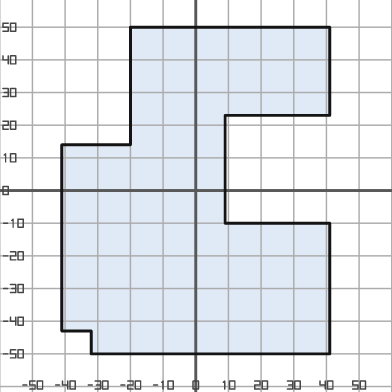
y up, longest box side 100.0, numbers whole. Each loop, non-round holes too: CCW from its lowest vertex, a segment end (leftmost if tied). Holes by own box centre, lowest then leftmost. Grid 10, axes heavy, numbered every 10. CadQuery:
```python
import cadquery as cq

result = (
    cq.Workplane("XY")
    .moveTo(-32.0, -50.0)
    .lineTo(41.0, -50.0)
    .lineTo(41.0, -10.0)
    .lineTo(9.0, -10.0)
    .lineTo(9.0, 23.0)
    .lineTo(41.0, 23.0)
    .lineTo(41.0, 50.0)
    .lineTo(-20.0, 50.0)
    .lineTo(-20.0, 14.0)
    .lineTo(-41.0, 14.0)
    .lineTo(-41.0, -43.0)
    .lineTo(-32.0, -43.0)
    .close()
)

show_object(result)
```